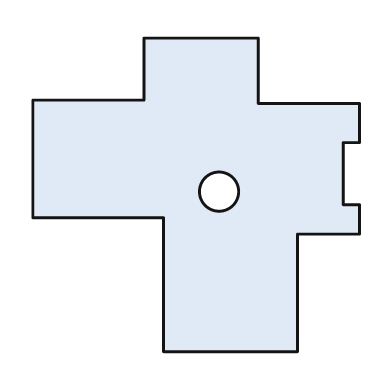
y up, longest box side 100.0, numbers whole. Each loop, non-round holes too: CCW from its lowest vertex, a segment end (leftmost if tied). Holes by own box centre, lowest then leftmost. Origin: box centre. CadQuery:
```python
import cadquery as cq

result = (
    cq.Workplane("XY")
    .moveTo(-10.0, -48.0)
    .lineTo(31.0, -48.0)
    .lineTo(31.0, -12.0)
    .lineTo(50.0, -12.0)
    .lineTo(50.0, -3.0)
    .lineTo(45.0, -3.0)
    .lineTo(45.0, 16.0)
    .lineTo(50.0, 16.0)
    .lineTo(50.0, 28.0)
    .lineTo(19.0, 28.0)
    .lineTo(19.0, 48.0)
    .lineTo(-16.0, 48.0)
    .lineTo(-16.0, 29.0)
    .lineTo(-50.0, 29.0)
    .lineTo(-50.0, -7.0)
    .lineTo(-10.0, -7.0)
    .close()
    .moveTo(7.0, 1.0)
    .circle(6.0)
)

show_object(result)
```